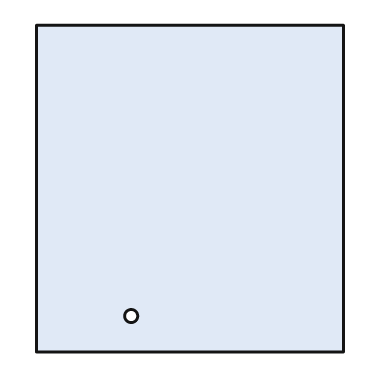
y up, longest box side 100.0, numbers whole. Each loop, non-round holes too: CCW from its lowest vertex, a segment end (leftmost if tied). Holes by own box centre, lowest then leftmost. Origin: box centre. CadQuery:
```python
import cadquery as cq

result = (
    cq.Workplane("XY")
    .moveTo(-47.0, -50.0)
    .lineTo(47.0, -50.0)
    .lineTo(47.0, 50.0)
    .lineTo(-47.0, 50.0)
    .close()
    .moveTo(-18.0, -39.0)
    .circle(2.0)
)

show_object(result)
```